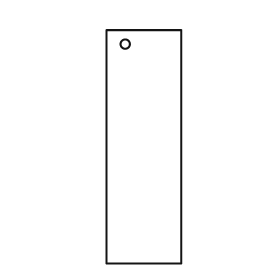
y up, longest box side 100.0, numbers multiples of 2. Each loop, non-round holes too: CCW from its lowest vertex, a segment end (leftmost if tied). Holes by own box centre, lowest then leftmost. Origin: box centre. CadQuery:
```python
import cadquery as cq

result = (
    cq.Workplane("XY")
    .moveTo(-16.0, -50.0)
    .lineTo(16.0, -50.0)
    .lineTo(16.0, 50.0)
    .lineTo(-16.0, 50.0)
    .close()
    .moveTo(-8.0, 44.0)
    .circle(2.0)
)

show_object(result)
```